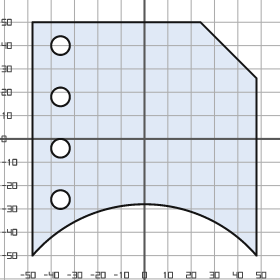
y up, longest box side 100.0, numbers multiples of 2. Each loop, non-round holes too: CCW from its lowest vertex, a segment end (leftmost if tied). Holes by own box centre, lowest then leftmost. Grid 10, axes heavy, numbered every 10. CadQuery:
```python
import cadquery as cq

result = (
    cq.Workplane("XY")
    .moveTo(-48.0, -50.0)
    .threePointArc((0.0, -28.0), (48.0, -50.0))
    .lineTo(48.0, 26.0)
    .lineTo(24.0, 50.0)
    .lineTo(-48.0, 50.0)
    .close()
    .moveTo(-36.0, -26.0)
    .circle(4.0)
    .moveTo(-36.0, -4.0)
    .circle(4.0)
    .moveTo(-36.0, 18.0)
    .circle(4.0)
    .moveTo(-36.0, 40.0)
    .circle(4.0)
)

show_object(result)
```